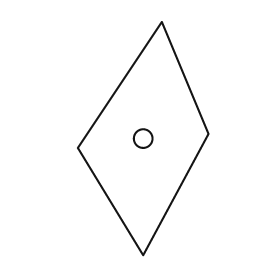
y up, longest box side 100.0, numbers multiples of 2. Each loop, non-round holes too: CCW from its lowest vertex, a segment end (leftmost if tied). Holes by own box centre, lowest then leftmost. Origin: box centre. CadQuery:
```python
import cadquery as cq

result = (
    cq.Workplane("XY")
    .moveTo(0.0, -50.0)
    .lineTo(28.0, 2.0)
    .lineTo(8.0, 50.0)
    .lineTo(-28.0, -4.0)
    .close()
    .moveTo(0.0, 0.0)
    .circle(4.0)
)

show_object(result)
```